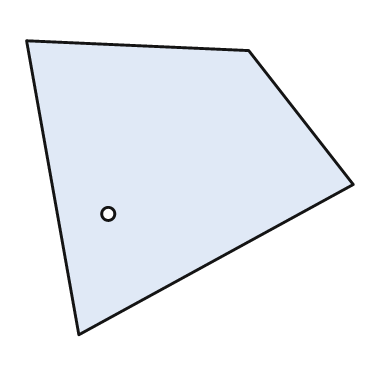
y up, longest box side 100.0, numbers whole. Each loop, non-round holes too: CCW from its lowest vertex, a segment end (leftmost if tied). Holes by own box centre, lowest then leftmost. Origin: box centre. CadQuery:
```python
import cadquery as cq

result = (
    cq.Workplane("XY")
    .moveTo(-34.0, -45.0)
    .lineTo(50.0, 1.0)
    .lineTo(18.0, 42.0)
    .lineTo(-50.0, 45.0)
    .close()
    .moveTo(-25.0, -8.0)
    .circle(2.0)
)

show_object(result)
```